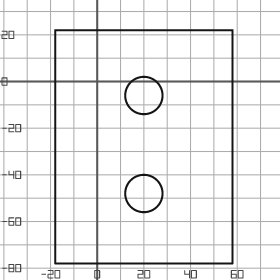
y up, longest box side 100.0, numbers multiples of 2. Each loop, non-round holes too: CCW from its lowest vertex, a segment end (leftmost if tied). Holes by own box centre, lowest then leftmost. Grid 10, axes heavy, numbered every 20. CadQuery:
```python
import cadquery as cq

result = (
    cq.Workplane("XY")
    .moveTo(-18.0, -78.0)
    .lineTo(58.0, -78.0)
    .lineTo(58.0, 22.0)
    .lineTo(-18.0, 22.0)
    .close()
    .moveTo(20.0, -48.0)
    .circle(8.0)
    .moveTo(20.0, -6.0)
    .circle(8.0)
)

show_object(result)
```